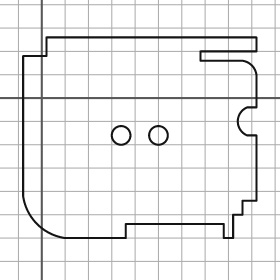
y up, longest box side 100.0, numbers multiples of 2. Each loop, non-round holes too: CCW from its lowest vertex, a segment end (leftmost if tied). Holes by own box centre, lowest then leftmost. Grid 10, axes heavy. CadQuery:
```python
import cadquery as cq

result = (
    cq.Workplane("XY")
    .moveTo(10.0, -60.0)
    .lineTo(36.0, -60.0)
    .lineTo(36.0, -54.0)
    .lineTo(78.0, -54.0)
    .lineTo(78.0, -60.0)
    .lineTo(82.0, -60.0)
    .lineTo(82.0, -50.0)
    .lineTo(86.0, -50.0)
    .lineTo(86.0, -44.0)
    .lineTo(92.0, -44.0)
    .lineTo(92.0, -16.0)
    .lineTo(88.0, -16.0)
    .threePointArc((84.0, -10.0), (88.0, -4.0))
    .lineTo(92.0, -4.0)
    .lineTo(92.0, 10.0)
    .threePointArc((90.0, 14.0), (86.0, 16.0))
    .lineTo(68.0, 16.0)
    .lineTo(68.0, 20.0)
    .lineTo(92.0, 20.0)
    .lineTo(92.0, 26.0)
    .lineTo(2.0, 26.0)
    .lineTo(2.0, 18.0)
    .lineTo(-8.0, 18.0)
    .lineTo(-8.0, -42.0)
    .threePointArc((-2.0, -54.0), (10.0, -60.0))
    .close()
    .moveTo(34.0, -16.0)
    .circle(4.0)
    .moveTo(50.0, -16.0)
    .circle(4.0)
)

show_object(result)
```